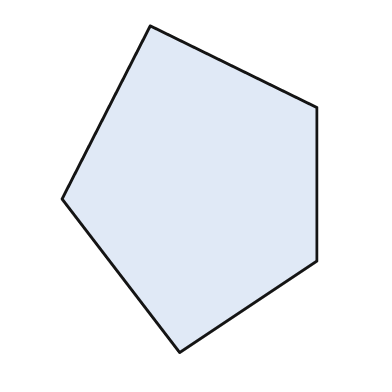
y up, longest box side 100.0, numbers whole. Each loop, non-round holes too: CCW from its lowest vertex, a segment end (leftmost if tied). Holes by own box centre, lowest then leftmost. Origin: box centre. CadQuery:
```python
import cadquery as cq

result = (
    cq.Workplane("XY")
    .moveTo(-3.0, -50.0)
    .lineTo(39.0, -22.0)
    .lineTo(39.0, 25.0)
    .lineTo(-12.0, 50.0)
    .lineTo(-39.0, -3.0)
    .close()
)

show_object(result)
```